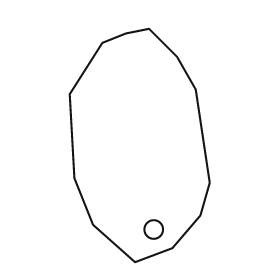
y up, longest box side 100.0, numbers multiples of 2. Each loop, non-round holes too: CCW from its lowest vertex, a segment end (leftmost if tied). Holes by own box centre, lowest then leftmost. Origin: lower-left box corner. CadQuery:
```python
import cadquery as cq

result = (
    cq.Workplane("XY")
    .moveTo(28.0, 0.0)
    .lineTo(44.0, 6.0)
    .lineTo(56.0, 20.0)
    .lineTo(60.0, 34.0)
    .lineTo(54.0, 74.0)
    .lineTo(46.0, 88.0)
    .lineTo(34.0, 100.0)
    .lineTo(24.0, 98.0)
    .lineTo(14.0, 94.0)
    .lineTo(0.0, 72.0)
    .lineTo(2.0, 36.0)
    .lineTo(10.0, 16.0)
    .close()
    .moveTo(36.0, 14.0)
    .circle(4.0)
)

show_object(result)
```